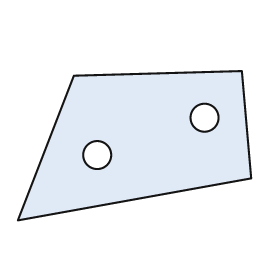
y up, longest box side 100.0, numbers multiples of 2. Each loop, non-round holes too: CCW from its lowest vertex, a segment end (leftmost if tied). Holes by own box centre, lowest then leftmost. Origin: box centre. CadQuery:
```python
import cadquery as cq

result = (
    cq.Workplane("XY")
    .moveTo(-50.0, -32.0)
    .lineTo(50.0, -14.0)
    .lineTo(46.0, 32.0)
    .lineTo(-26.0, 30.0)
    .close()
    .moveTo(-16.0, -4.0)
    .circle(6.0)
    .moveTo(30.0, 12.0)
    .circle(6.0)
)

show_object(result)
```